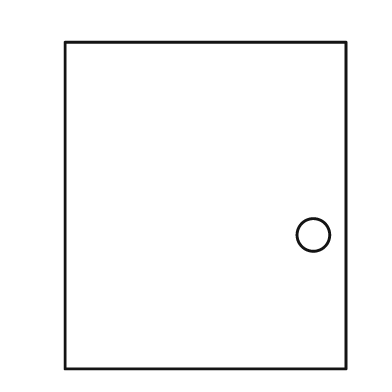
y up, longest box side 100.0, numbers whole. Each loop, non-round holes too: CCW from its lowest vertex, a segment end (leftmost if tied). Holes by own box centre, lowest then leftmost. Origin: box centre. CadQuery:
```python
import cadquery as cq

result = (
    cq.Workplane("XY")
    .moveTo(-43.0, -50.0)
    .lineTo(43.0, -50.0)
    .lineTo(43.0, 50.0)
    .lineTo(-43.0, 50.0)
    .close()
    .moveTo(33.0, -9.0)
    .circle(5.0)
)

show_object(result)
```